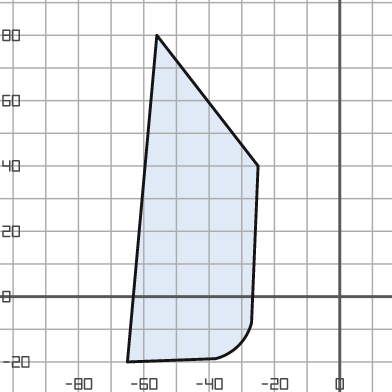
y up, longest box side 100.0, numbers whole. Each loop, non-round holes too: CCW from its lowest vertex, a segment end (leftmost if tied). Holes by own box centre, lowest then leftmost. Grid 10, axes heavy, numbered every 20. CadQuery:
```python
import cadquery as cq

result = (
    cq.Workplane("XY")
    .moveTo(-65.0, -20.0)
    .lineTo(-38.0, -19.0)
    .threePointArc((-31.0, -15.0), (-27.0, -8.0))
    .lineTo(-25.0, 40.0)
    .lineTo(-56.0, 80.0)
    .close()
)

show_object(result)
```